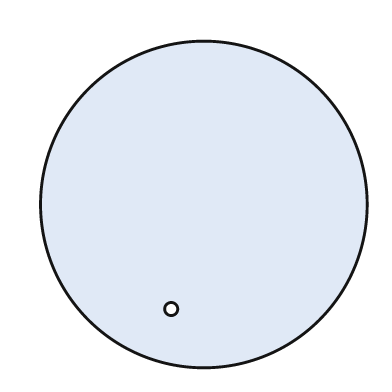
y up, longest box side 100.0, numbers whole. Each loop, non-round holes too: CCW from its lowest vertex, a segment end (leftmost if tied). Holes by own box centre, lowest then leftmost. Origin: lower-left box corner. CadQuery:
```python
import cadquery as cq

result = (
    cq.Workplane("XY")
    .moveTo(50.0, 50.0)
    .circle(50.0)
    .moveTo(40.0, 18.0)
    .circle(2.0)
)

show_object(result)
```